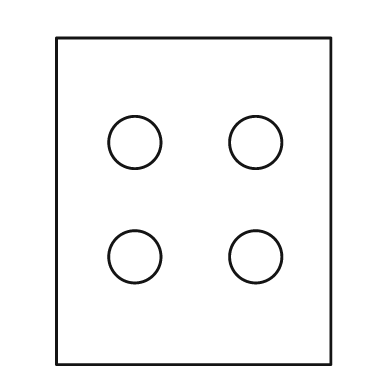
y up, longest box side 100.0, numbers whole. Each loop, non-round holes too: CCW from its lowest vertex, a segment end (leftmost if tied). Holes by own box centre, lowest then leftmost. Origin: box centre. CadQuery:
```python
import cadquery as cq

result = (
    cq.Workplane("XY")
    .moveTo(-42.0, -50.0)
    .lineTo(42.0, -50.0)
    .lineTo(42.0, 50.0)
    .lineTo(-42.0, 50.0)
    .close()
    .moveTo(-18.0, -17.0)
    .circle(8.0)
    .moveTo(19.0, -17.0)
    .circle(8.0)
    .moveTo(-18.0, 18.0)
    .circle(8.0)
    .moveTo(19.0, 18.0)
    .circle(8.0)
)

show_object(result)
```